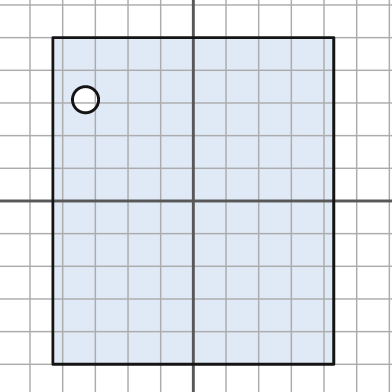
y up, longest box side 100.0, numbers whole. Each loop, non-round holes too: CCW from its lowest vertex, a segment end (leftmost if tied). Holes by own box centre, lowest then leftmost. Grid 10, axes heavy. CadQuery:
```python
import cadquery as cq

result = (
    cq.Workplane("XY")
    .moveTo(-43.0, -50.0)
    .lineTo(43.0, -50.0)
    .lineTo(43.0, 50.0)
    .lineTo(-43.0, 50.0)
    .close()
    .moveTo(-33.0, 31.0)
    .circle(4.0)
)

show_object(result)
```